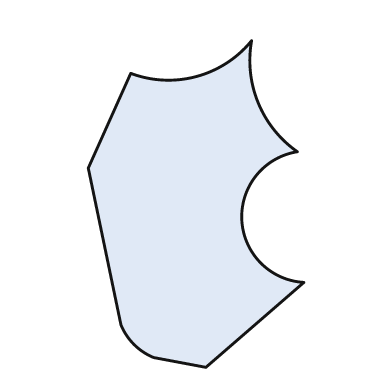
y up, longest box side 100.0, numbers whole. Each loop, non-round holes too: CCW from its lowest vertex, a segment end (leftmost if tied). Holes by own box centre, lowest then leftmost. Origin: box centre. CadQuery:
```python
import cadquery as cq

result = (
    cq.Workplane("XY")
    .moveTo(3.0, -50.0)
    .lineTo(33.0, -24.0)
    .threePointArc((14.0, -5.0), (31.0, 16.0))
    .threePointArc((19.0, 31.0), (17.0, 50.0))
    .threePointArc((0.0, 39.0), (-20.0, 40.0))
    .lineTo(-33.0, 11.0)
    .lineTo(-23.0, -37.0)
    .threePointArc((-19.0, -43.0), (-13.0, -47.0))
    .close()
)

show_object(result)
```